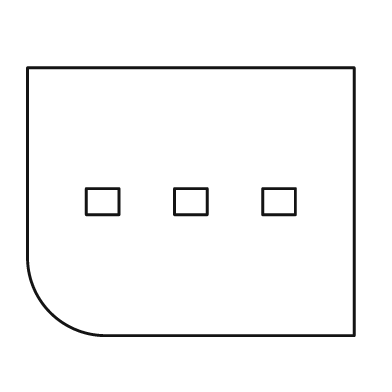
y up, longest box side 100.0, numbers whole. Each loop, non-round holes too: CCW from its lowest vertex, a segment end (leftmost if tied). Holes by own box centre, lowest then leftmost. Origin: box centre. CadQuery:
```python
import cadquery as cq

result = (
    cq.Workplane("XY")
    .moveTo(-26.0, -41.0)
    .lineTo(50.0, -41.0)
    .lineTo(50.0, 41.0)
    .lineTo(-50.0, 41.0)
    .lineTo(-50.0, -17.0)
    .threePointArc((-43.0, -34.0), (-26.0, -41.0))
    .close()
    .moveTo(-32.0, -4.0)
    .lineTo(-22.0, -4.0)
    .lineTo(-22.0, 4.0)
    .lineTo(-32.0, 4.0)
    .close()
    .moveTo(-5.0, -4.0)
    .lineTo(5.0, -4.0)
    .lineTo(5.0, 4.0)
    .lineTo(-5.0, 4.0)
    .close()
    .moveTo(22.0, -4.0)
    .lineTo(32.0, -4.0)
    .lineTo(32.0, 4.0)
    .lineTo(22.0, 4.0)
    .close()
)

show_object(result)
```